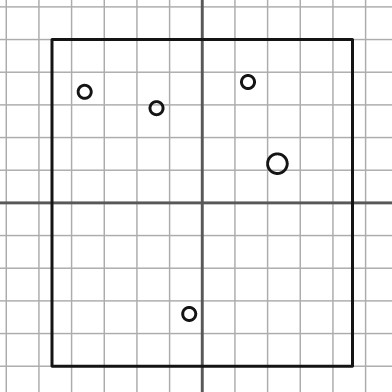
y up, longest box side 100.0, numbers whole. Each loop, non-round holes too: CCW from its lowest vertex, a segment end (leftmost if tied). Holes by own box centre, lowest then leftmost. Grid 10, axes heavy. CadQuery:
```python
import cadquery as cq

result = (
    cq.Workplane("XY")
    .moveTo(-46.0, -50.0)
    .lineTo(46.0, -50.0)
    .lineTo(46.0, 50.0)
    .lineTo(-46.0, 50.0)
    .close()
    .moveTo(-4.0, -34.0)
    .circle(2.0)
    .moveTo(23.0, 12.0)
    .circle(3.0)
    .moveTo(-14.0, 29.0)
    .circle(2.0)
    .moveTo(-36.0, 34.0)
    .circle(2.0)
    .moveTo(14.0, 37.0)
    .circle(2.0)
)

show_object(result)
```